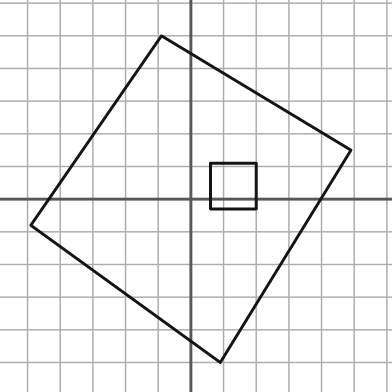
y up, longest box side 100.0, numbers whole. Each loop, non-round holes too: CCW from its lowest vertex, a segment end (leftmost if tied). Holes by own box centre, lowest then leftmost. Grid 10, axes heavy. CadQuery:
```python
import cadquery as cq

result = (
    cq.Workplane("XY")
    .moveTo(9.0, -50.0)
    .lineTo(49.0, 15.0)
    .lineTo(-9.0, 50.0)
    .lineTo(-49.0, -8.0)
    .close()
    .moveTo(6.0, -3.0)
    .lineTo(20.0, -3.0)
    .lineTo(20.0, 11.0)
    .lineTo(6.0, 11.0)
    .close()
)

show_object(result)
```